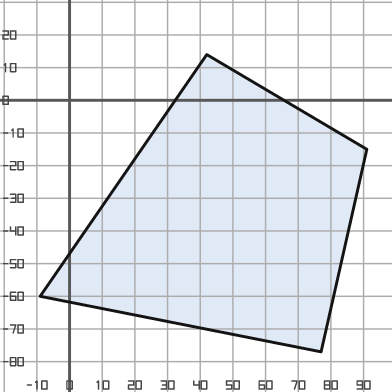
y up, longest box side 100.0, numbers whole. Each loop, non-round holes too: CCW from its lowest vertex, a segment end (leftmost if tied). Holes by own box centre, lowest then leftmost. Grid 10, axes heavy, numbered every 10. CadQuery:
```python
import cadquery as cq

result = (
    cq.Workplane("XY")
    .moveTo(77.0, -77.0)
    .lineTo(91.0, -15.0)
    .lineTo(42.0, 14.0)
    .lineTo(-9.0, -60.0)
    .close()
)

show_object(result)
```